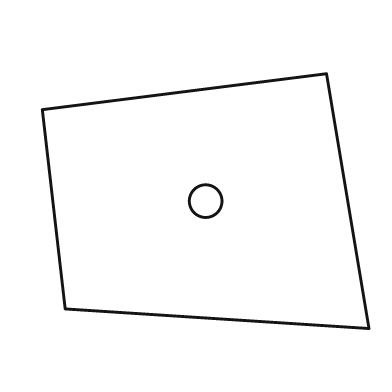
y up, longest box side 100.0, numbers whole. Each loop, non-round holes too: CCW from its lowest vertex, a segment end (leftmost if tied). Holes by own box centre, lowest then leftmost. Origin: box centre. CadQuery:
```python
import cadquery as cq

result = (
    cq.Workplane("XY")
    .moveTo(50.0, -39.0)
    .lineTo(37.0, 39.0)
    .lineTo(-50.0, 28.0)
    .lineTo(-43.0, -33.0)
    .close()
    .moveTo(0.0, 0.0)
    .circle(5.0)
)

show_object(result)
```